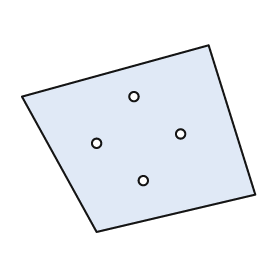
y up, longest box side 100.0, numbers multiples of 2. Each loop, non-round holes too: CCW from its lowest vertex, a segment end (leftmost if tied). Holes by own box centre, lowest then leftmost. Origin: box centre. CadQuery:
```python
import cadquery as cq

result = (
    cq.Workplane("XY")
    .moveTo(-18.0, -40.0)
    .lineTo(50.0, -24.0)
    .lineTo(30.0, 40.0)
    .lineTo(-50.0, 18.0)
    .close()
    .moveTo(2.0, -18.0)
    .circle(2.0)
    .moveTo(-18.0, -2.0)
    .circle(2.0)
    .moveTo(18.0, 2.0)
    .circle(2.0)
    .moveTo(-2.0, 18.0)
    .circle(2.0)
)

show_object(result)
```